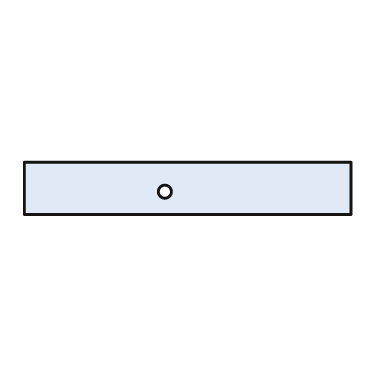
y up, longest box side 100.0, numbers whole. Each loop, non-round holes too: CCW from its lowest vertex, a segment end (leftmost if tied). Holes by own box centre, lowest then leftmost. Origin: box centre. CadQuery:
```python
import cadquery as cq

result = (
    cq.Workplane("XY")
    .moveTo(-50.0, -8.0)
    .lineTo(50.0, -8.0)
    .lineTo(50.0, 8.0)
    .lineTo(-50.0, 8.0)
    .close()
    .moveTo(-7.0, -1.0)
    .circle(2.0)
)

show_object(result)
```